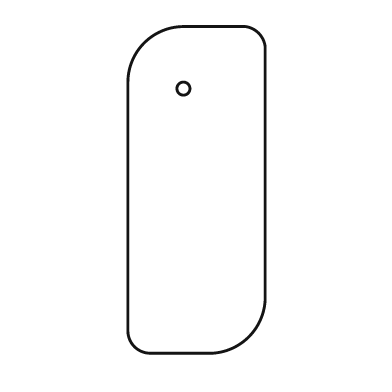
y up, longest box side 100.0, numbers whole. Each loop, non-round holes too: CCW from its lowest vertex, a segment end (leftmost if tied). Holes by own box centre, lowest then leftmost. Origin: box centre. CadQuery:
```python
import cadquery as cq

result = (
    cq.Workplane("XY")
    .moveTo(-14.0, -50.0)
    .lineTo(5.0, -50.0)
    .threePointArc((16.0, -45.0), (21.0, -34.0))
    .lineTo(21.0, 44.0)
    .threePointArc((19.0, 48.0), (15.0, 50.0))
    .lineTo(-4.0, 50.0)
    .threePointArc((-16.0, 45.0), (-21.0, 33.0))
    .lineTo(-21.0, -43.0)
    .threePointArc((-19.0, -48.0), (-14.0, -50.0))
    .close()
    .moveTo(-4.0, 31.0)
    .circle(2.0)
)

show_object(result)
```